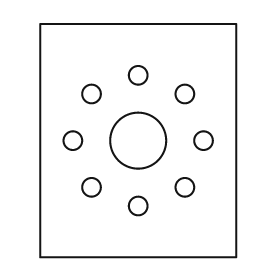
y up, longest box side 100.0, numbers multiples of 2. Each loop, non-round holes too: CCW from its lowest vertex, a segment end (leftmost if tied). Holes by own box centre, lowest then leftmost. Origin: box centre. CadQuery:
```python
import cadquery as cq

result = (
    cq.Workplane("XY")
    .moveTo(-42.0, -50.0)
    .lineTo(42.0, -50.0)
    .lineTo(42.0, 50.0)
    .lineTo(-42.0, 50.0)
    .close()
    .moveTo(0.0, -28.0)
    .circle(4.0)
    .moveTo(-20.0, -20.0)
    .circle(4.0)
    .moveTo(20.0, -20.0)
    .circle(4.0)
    .moveTo(-28.0, 0.0)
    .circle(4.0)
    .moveTo(0.0, 0.0)
    .circle(12.0)
    .moveTo(28.0, 0.0)
    .circle(4.0)
    .moveTo(-20.0, 20.0)
    .circle(4.0)
    .moveTo(20.0, 20.0)
    .circle(4.0)
    .moveTo(0.0, 28.0)
    .circle(4.0)
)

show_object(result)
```